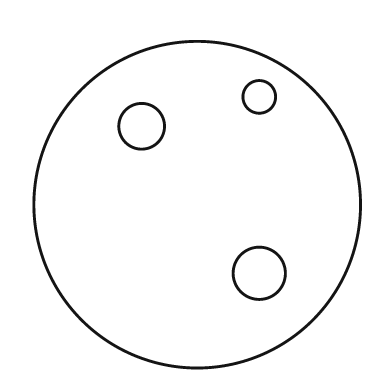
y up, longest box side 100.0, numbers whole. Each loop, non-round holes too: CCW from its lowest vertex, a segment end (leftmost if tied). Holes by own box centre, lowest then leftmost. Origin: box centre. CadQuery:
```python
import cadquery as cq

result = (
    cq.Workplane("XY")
    .moveTo(0.0, 0.0)
    .circle(50.0)
    .moveTo(19.0, -21.0)
    .circle(8.0)
    .moveTo(-17.0, 24.0)
    .circle(7.0)
    .moveTo(19.0, 33.0)
    .circle(5.0)
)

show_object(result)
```